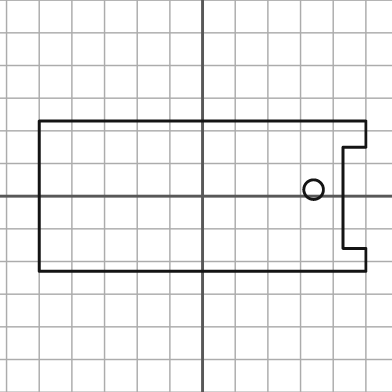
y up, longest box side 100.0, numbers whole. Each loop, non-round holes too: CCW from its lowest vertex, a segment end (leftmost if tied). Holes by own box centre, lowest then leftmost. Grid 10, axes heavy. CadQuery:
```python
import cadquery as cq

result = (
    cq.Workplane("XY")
    .moveTo(-50.0, -23.0)
    .lineTo(50.0, -23.0)
    .lineTo(50.0, -16.0)
    .lineTo(43.0, -16.0)
    .lineTo(43.0, 15.0)
    .lineTo(50.0, 15.0)
    .lineTo(50.0, 23.0)
    .lineTo(-50.0, 23.0)
    .close()
    .moveTo(34.0, 2.0)
    .circle(3.0)
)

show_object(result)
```